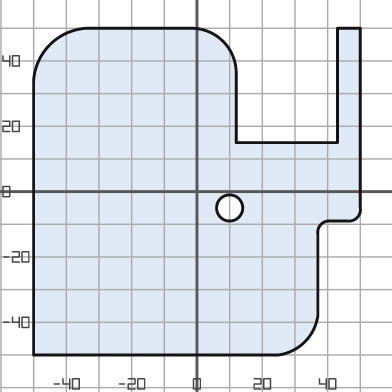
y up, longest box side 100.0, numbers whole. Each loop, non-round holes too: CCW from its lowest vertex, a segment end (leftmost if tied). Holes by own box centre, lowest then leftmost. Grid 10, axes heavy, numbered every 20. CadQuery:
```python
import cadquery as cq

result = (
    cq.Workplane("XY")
    .moveTo(-50.0, -50.0)
    .lineTo(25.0, -50.0)
    .threePointArc((33.0, -46.0), (37.0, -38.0))
    .lineTo(37.0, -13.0)
    .threePointArc((38.0, -10.0), (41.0, -9.0))
    .lineTo(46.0, -9.0)
    .threePointArc((49.0, -8.0), (50.0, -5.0))
    .lineTo(50.0, 50.0)
    .lineTo(43.0, 50.0)
    .lineTo(43.0, 15.0)
    .lineTo(12.0, 15.0)
    .lineTo(12.0, 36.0)
    .threePointArc((8.0, 46.0), (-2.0, 50.0))
    .lineTo(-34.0, 50.0)
    .threePointArc((-45.0, 45.0), (-50.0, 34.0))
    .close()
    .moveTo(10.0, -5.0)
    .circle(4.0)
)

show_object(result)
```